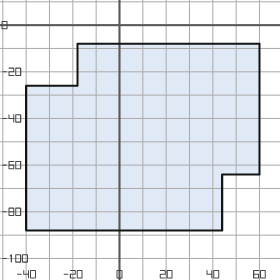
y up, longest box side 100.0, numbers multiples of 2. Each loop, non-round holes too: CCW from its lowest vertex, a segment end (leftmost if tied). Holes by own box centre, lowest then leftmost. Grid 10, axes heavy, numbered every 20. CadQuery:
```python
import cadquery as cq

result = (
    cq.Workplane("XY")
    .moveTo(-40.0, -88.0)
    .lineTo(44.0, -88.0)
    .lineTo(44.0, -64.0)
    .lineTo(60.0, -64.0)
    .lineTo(60.0, -8.0)
    .lineTo(-18.0, -8.0)
    .lineTo(-18.0, -26.0)
    .lineTo(-40.0, -26.0)
    .close()
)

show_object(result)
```